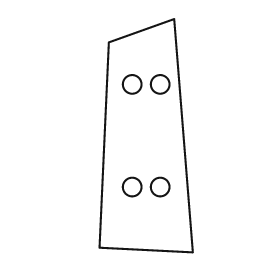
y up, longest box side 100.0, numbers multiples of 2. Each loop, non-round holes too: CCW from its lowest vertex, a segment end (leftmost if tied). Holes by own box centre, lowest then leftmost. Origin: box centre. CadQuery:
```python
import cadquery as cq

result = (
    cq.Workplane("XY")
    .moveTo(20.0, -50.0)
    .lineTo(12.0, 50.0)
    .lineTo(-16.0, 40.0)
    .lineTo(-20.0, -48.0)
    .close()
    .moveTo(-6.0, -22.0)
    .circle(4.0)
    .moveTo(6.0, -22.0)
    .circle(4.0)
    .moveTo(-6.0, 22.0)
    .circle(4.0)
    .moveTo(6.0, 22.0)
    .circle(4.0)
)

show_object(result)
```